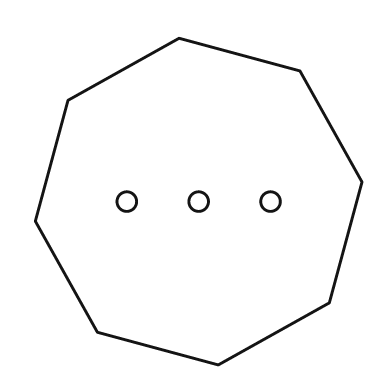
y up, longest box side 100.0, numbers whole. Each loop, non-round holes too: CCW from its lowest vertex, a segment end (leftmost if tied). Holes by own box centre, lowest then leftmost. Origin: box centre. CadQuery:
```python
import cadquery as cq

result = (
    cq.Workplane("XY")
    .moveTo(6.0, -50.0)
    .lineTo(40.0, -31.0)
    .lineTo(50.0, 6.0)
    .lineTo(31.0, 40.0)
    .lineTo(-6.0, 50.0)
    .lineTo(-40.0, 31.0)
    .lineTo(-50.0, -6.0)
    .lineTo(-31.0, -40.0)
    .close()
    .moveTo(-22.0, 0.0)
    .circle(3.0)
    .moveTo(0.0, 0.0)
    .circle(3.0)
    .moveTo(22.0, 0.0)
    .circle(3.0)
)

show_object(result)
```